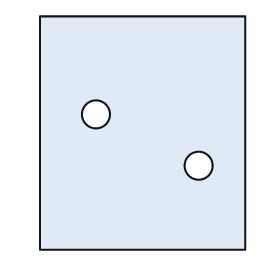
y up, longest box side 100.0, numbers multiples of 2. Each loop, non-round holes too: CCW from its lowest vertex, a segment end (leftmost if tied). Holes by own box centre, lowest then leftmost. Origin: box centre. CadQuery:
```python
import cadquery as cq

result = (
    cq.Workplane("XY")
    .moveTo(-44.0, -50.0)
    .lineTo(44.0, -50.0)
    .lineTo(44.0, 50.0)
    .lineTo(-44.0, 50.0)
    .close()
    .moveTo(24.0, -14.0)
    .circle(6.0)
    .moveTo(-20.0, 8.0)
    .circle(6.0)
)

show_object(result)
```